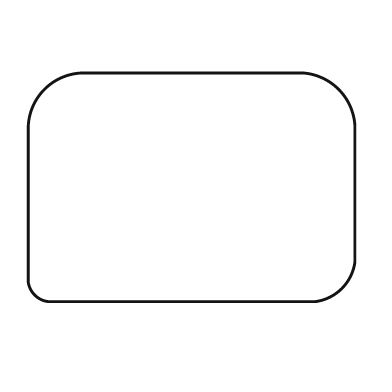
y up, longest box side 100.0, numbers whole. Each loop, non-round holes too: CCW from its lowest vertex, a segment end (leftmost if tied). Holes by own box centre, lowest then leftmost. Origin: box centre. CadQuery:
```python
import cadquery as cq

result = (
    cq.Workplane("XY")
    .moveTo(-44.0, -35.0)
    .lineTo(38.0, -35.0)
    .threePointArc((46.0, -31.0), (50.0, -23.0))
    .lineTo(50.0, 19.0)
    .threePointArc((45.0, 30.0), (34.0, 35.0))
    .lineTo(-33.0, 35.0)
    .threePointArc((-45.0, 30.0), (-50.0, 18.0))
    .lineTo(-50.0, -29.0)
    .threePointArc((-48.0, -33.0), (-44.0, -35.0))
    .close()
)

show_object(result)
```